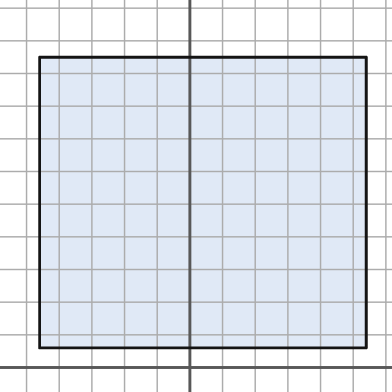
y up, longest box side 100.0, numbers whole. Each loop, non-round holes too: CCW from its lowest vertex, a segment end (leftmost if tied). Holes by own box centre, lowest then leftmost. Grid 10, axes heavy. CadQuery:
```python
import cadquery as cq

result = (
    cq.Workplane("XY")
    .moveTo(-46.0, 6.0)
    .lineTo(54.0, 6.0)
    .lineTo(54.0, 95.0)
    .lineTo(-46.0, 95.0)
    .close()
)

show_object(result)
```